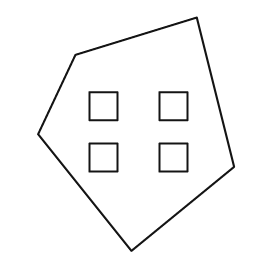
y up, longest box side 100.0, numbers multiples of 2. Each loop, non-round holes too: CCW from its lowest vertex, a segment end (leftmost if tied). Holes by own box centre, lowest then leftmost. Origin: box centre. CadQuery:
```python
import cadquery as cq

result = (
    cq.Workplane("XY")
    .moveTo(-2.0, -50.0)
    .lineTo(42.0, -14.0)
    .lineTo(26.0, 50.0)
    .lineTo(-26.0, 34.0)
    .lineTo(-42.0, 0.0)
    .close()
    .moveTo(-20.0, -16.0)
    .lineTo(-8.0, -16.0)
    .lineTo(-8.0, -4.0)
    .lineTo(-20.0, -4.0)
    .close()
    .moveTo(10.0, -16.0)
    .lineTo(22.0, -16.0)
    .lineTo(22.0, -4.0)
    .lineTo(10.0, -4.0)
    .close()
    .moveTo(-20.0, 6.0)
    .lineTo(-8.0, 6.0)
    .lineTo(-8.0, 18.0)
    .lineTo(-20.0, 18.0)
    .close()
    .moveTo(10.0, 6.0)
    .lineTo(22.0, 6.0)
    .lineTo(22.0, 18.0)
    .lineTo(10.0, 18.0)
    .close()
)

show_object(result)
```